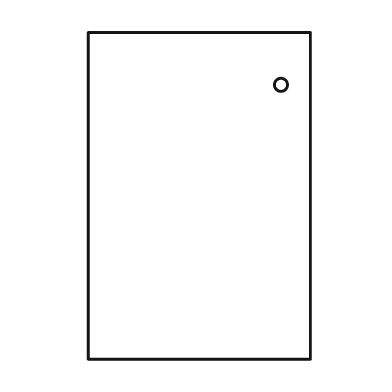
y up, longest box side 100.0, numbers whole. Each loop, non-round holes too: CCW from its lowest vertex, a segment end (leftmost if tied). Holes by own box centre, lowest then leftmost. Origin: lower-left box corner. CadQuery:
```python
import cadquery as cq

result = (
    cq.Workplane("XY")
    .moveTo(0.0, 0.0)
    .lineTo(68.0, 0.0)
    .lineTo(68.0, 100.0)
    .lineTo(0.0, 100.0)
    .close()
    .moveTo(59.0, 84.0)
    .circle(2.0)
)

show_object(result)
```